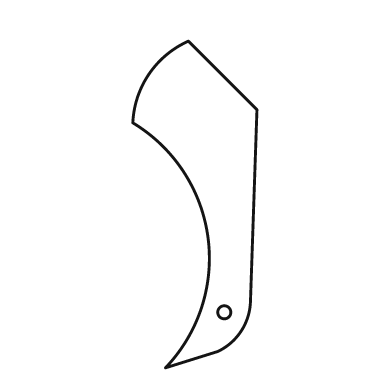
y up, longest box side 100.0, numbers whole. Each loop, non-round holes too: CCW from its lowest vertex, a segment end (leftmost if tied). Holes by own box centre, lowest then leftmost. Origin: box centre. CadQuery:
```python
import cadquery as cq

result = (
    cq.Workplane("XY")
    .moveTo(-9.0, -50.0)
    .lineTo(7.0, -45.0)
    .threePointArc((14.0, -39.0), (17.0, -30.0))
    .lineTo(19.0, 29.0)
    .lineTo(-2.0, 50.0)
    .threePointArc((-14.0, 40.0), (-19.0, 25.0))
    .threePointArc((4.0, -10.0), (-9.0, -50.0))
    .close()
    .moveTo(9.0, -33.0)
    .circle(2.0)
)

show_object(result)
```